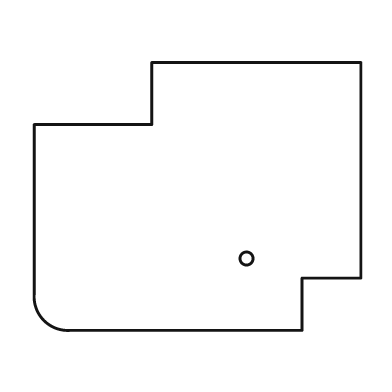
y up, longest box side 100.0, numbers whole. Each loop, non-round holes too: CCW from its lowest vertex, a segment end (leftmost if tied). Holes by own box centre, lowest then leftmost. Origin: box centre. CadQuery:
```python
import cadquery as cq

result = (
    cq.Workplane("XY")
    .moveTo(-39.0, -41.0)
    .lineTo(32.0, -41.0)
    .lineTo(32.0, -25.0)
    .lineTo(50.0, -25.0)
    .lineTo(50.0, 41.0)
    .lineTo(-14.0, 41.0)
    .lineTo(-14.0, 22.0)
    .lineTo(-50.0, 22.0)
    .lineTo(-50.0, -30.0)
    .threePointArc((-47.0, -38.0), (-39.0, -41.0))
    .close()
    .moveTo(15.0, -19.0)
    .circle(2.0)
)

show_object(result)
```